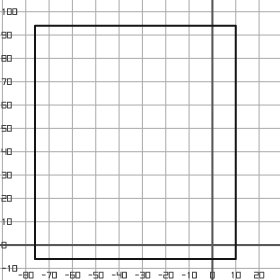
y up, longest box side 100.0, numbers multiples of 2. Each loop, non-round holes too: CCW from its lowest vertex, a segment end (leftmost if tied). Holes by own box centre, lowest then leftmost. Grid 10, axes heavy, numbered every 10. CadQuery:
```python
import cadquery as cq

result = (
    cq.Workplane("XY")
    .moveTo(-76.0, -6.0)
    .lineTo(10.0, -6.0)
    .lineTo(10.0, 94.0)
    .lineTo(-76.0, 94.0)
    .close()
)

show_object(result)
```